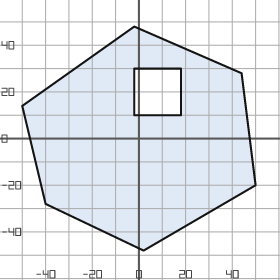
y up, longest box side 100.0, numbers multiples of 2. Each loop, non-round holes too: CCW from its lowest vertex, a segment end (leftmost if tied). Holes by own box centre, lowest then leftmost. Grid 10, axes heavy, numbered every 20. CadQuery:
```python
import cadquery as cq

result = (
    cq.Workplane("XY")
    .moveTo(2.0, -48.0)
    .lineTo(50.0, -20.0)
    .lineTo(44.0, 28.0)
    .lineTo(-2.0, 48.0)
    .lineTo(-50.0, 14.0)
    .lineTo(-40.0, -28.0)
    .close()
    .moveTo(-2.0, 10.0)
    .lineTo(18.0, 10.0)
    .lineTo(18.0, 30.0)
    .lineTo(-2.0, 30.0)
    .close()
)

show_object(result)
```